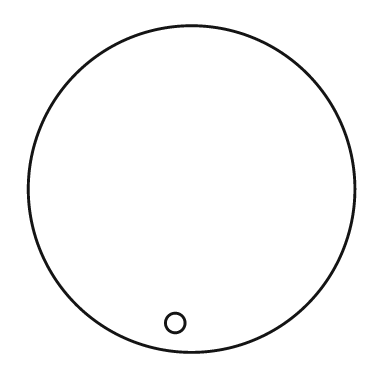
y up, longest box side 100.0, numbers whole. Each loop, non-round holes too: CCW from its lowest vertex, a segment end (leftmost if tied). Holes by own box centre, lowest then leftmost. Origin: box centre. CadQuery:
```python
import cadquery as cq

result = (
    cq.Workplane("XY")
    .moveTo(0.0, 0.0)
    .circle(50.0)
    .moveTo(-5.0, -41.0)
    .circle(3.0)
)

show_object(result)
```